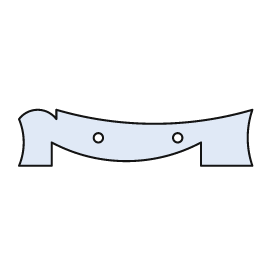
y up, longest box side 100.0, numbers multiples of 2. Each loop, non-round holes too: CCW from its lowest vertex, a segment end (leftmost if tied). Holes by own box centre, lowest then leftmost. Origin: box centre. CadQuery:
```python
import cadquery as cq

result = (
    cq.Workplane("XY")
    .moveTo(-50.0, -12.0)
    .lineTo(-36.0, -12.0)
    .lineTo(-36.0, -2.0)
    .threePointArc((-4.0, -10.0), (28.0, -2.0))
    .lineTo(28.0, -12.0)
    .lineTo(50.0, -12.0)
    .threePointArc((48.0, 0.0), (50.0, 12.0))
    .threePointArc((8.0, 6.0), (-34.0, 12.0))
    .lineTo(-34.0, 8.0)
    .threePointArc((-42.0, 12.0), (-50.0, 8.0))
    .threePointArc((-48.0, -2.0), (-50.0, -12.0))
    .close()
    .moveTo(-16.0, 0.0)
    .circle(2.0)
    .moveTo(18.0, 0.0)
    .circle(2.0)
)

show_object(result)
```